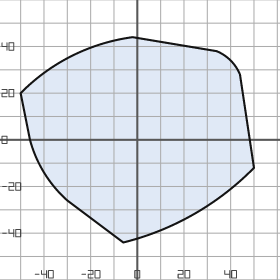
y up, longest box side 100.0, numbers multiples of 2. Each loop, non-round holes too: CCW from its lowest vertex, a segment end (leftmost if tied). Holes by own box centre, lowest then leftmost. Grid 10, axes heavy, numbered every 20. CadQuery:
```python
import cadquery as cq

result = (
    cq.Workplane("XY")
    .moveTo(-6.0, -44.0)
    .threePointArc((24.0, -32.0), (50.0, -12.0))
    .lineTo(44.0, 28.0)
    .threePointArc((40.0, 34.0), (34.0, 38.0))
    .lineTo(-2.0, 44.0)
    .threePointArc((-28.0, 36.0), (-50.0, 20.0))
    .lineTo(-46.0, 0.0)
    .threePointArc((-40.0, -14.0), (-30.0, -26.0))
    .close()
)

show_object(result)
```